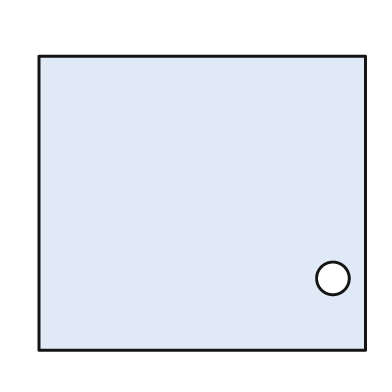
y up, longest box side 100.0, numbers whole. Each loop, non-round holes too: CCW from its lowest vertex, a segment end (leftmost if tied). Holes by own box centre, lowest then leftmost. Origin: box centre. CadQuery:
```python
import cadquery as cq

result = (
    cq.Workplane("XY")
    .moveTo(-50.0, -45.0)
    .lineTo(50.0, -45.0)
    .lineTo(50.0, 45.0)
    .lineTo(-50.0, 45.0)
    .close()
    .moveTo(40.0, -23.0)
    .circle(5.0)
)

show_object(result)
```